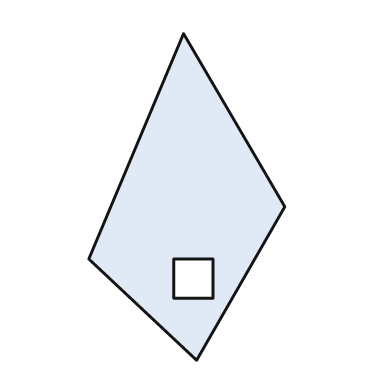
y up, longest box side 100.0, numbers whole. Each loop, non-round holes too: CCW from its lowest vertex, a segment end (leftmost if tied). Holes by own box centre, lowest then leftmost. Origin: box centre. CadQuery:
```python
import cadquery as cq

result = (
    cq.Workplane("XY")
    .moveTo(3.0, -50.0)
    .lineTo(30.0, -3.0)
    .lineTo(-1.0, 50.0)
    .lineTo(-30.0, -19.0)
    .close()
    .moveTo(-4.0, -31.0)
    .lineTo(8.0, -31.0)
    .lineTo(8.0, -19.0)
    .lineTo(-4.0, -19.0)
    .close()
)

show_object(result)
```